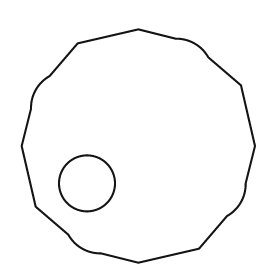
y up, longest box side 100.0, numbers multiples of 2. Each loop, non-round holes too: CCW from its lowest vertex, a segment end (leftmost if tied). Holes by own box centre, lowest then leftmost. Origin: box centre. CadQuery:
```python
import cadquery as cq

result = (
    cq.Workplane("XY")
    .moveTo(0.0, -50.0)
    .lineTo(26.0, -44.0)
    .lineTo(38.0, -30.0)
    .threePointArc((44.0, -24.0), (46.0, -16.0))
    .lineTo(50.0, 0.0)
    .lineTo(44.0, 26.0)
    .lineTo(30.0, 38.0)
    .threePointArc((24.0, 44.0), (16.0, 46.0))
    .lineTo(0.0, 50.0)
    .lineTo(-26.0, 44.0)
    .lineTo(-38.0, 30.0)
    .threePointArc((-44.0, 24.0), (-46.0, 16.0))
    .lineTo(-50.0, 0.0)
    .lineTo(-44.0, -26.0)
    .lineTo(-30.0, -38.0)
    .threePointArc((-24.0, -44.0), (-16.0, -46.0))
    .close()
    .moveTo(-22.0, -16.0)
    .circle(12.0)
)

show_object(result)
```